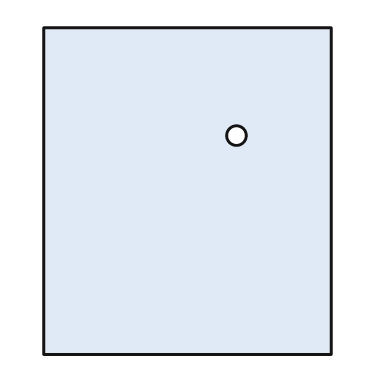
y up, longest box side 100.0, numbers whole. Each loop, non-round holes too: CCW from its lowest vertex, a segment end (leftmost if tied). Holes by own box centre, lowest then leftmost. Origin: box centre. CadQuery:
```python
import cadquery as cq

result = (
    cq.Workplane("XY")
    .moveTo(-44.0, -50.0)
    .lineTo(44.0, -50.0)
    .lineTo(44.0, 50.0)
    .lineTo(-44.0, 50.0)
    .close()
    .moveTo(15.0, 17.0)
    .circle(3.0)
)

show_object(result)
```